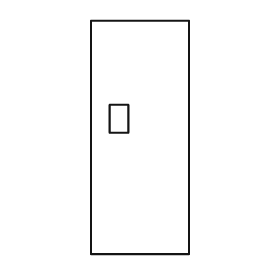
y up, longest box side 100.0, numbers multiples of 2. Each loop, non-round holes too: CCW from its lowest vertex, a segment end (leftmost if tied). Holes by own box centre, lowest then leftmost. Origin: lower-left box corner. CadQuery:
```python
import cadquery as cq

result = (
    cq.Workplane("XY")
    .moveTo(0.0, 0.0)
    .lineTo(42.0, 0.0)
    .lineTo(42.0, 100.0)
    .lineTo(0.0, 100.0)
    .close()
    .moveTo(8.0, 52.0)
    .lineTo(16.0, 52.0)
    .lineTo(16.0, 64.0)
    .lineTo(8.0, 64.0)
    .close()
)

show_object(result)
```